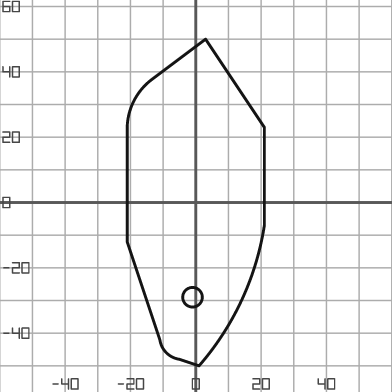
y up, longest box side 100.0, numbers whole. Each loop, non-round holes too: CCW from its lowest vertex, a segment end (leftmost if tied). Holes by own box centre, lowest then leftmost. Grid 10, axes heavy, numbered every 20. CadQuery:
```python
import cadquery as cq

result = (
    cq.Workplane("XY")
    .moveTo(1.0, -50.0)
    .threePointArc((14.0, -30.0), (21.0, -7.0))
    .lineTo(21.0, 23.0)
    .lineTo(3.0, 50.0)
    .lineTo(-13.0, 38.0)
    .threePointArc((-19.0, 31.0), (-21.0, 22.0))
    .lineTo(-21.0, -12.0)
    .lineTo(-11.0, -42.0)
    .threePointArc((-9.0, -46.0), (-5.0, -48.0))
    .close()
    .moveTo(-1.0, -29.0)
    .circle(3.0)
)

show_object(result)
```